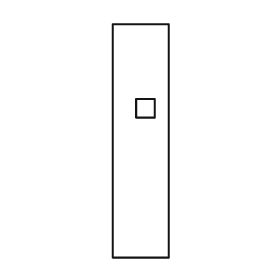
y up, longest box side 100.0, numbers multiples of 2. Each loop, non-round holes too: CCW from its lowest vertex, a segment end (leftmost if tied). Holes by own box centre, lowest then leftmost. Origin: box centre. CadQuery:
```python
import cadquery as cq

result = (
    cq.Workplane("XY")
    .moveTo(-12.0, -50.0)
    .lineTo(12.0, -50.0)
    .lineTo(12.0, 50.0)
    .lineTo(-12.0, 50.0)
    .close()
    .moveTo(-2.0, 10.0)
    .lineTo(6.0, 10.0)
    .lineTo(6.0, 18.0)
    .lineTo(-2.0, 18.0)
    .close()
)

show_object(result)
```